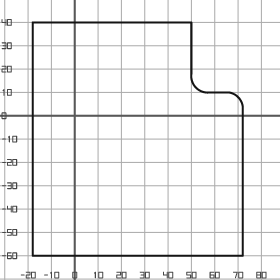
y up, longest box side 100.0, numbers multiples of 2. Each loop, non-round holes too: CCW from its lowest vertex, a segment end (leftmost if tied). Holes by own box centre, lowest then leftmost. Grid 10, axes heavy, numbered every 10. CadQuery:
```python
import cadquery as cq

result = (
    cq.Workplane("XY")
    .moveTo(-18.0, -60.0)
    .lineTo(72.0, -60.0)
    .lineTo(72.0, 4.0)
    .threePointArc((70.0, 8.0), (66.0, 10.0))
    .lineTo(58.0, 10.0)
    .threePointArc((52.0, 12.0), (50.0, 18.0))
    .lineTo(50.0, 40.0)
    .lineTo(-18.0, 40.0)
    .close()
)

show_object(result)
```